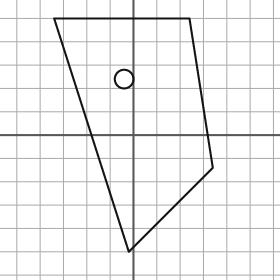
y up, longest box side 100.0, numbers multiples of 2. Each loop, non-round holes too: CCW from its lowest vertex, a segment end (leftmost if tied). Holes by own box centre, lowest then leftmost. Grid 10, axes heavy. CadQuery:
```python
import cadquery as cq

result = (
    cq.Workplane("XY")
    .moveTo(-2.0, -50.0)
    .lineTo(34.0, -14.0)
    .lineTo(24.0, 50.0)
    .lineTo(-34.0, 50.0)
    .close()
    .moveTo(-4.0, 24.0)
    .circle(4.0)
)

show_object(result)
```